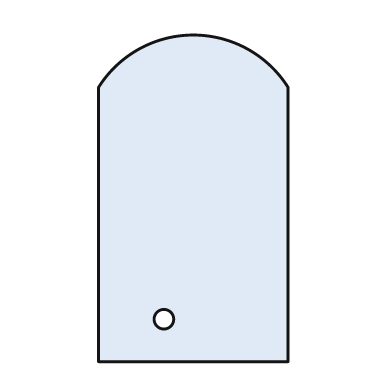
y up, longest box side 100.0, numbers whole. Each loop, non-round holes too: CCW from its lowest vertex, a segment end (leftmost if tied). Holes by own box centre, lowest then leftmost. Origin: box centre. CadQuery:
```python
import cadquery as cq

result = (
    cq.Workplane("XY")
    .moveTo(-29.0, -50.0)
    .lineTo(29.0, -50.0)
    .lineTo(29.0, 34.0)
    .threePointArc((0.0, 50.0), (-29.0, 34.0))
    .close()
    .moveTo(-9.0, -37.0)
    .circle(3.0)
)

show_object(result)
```